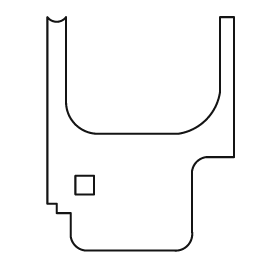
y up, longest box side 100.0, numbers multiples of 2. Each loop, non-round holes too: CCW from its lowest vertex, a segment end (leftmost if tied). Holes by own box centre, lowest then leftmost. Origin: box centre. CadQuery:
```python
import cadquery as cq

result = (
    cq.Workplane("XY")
    .moveTo(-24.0, -50.0)
    .lineTo(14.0, -50.0)
    .threePointArc((20.0, -48.0), (22.0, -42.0))
    .lineTo(22.0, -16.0)
    .threePointArc((24.0, -12.0), (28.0, -10.0))
    .lineTo(40.0, -10.0)
    .lineTo(40.0, 50.0)
    .lineTo(34.0, 50.0)
    .lineTo(34.0, 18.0)
    .threePointArc((28.0, 6.0), (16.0, 0.0))
    .lineTo(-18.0, 0.0)
    .threePointArc((-28.0, 4.0), (-32.0, 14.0))
    .lineTo(-32.0, 50.0)
    .threePointArc((-36.0, 48.0), (-40.0, 50.0))
    .lineTo(-40.0, -30.0)
    .lineTo(-36.0, -30.0)
    .lineTo(-36.0, -34.0)
    .lineTo(-30.0, -34.0)
    .lineTo(-30.0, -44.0)
    .threePointArc((-28.0, -48.0), (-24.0, -50.0))
    .close()
    .moveTo(-28.0, -26.0)
    .lineTo(-20.0, -26.0)
    .lineTo(-20.0, -18.0)
    .lineTo(-28.0, -18.0)
    .close()
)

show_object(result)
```